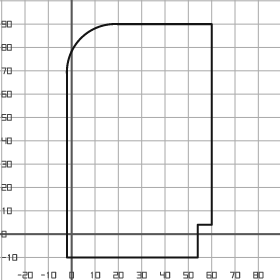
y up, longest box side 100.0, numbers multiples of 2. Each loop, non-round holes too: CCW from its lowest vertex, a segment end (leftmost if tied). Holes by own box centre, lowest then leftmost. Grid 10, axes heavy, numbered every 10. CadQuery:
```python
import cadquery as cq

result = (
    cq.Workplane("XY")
    .moveTo(-2.0, -10.0)
    .lineTo(54.0, -10.0)
    .lineTo(54.0, 4.0)
    .lineTo(60.0, 4.0)
    .lineTo(60.0, 90.0)
    .lineTo(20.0, 90.0)
    .threePointArc((4.0, 84.0), (-2.0, 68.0))
    .close()
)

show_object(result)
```